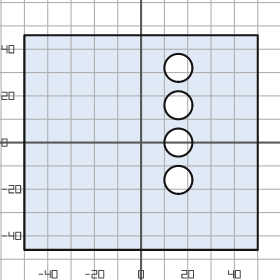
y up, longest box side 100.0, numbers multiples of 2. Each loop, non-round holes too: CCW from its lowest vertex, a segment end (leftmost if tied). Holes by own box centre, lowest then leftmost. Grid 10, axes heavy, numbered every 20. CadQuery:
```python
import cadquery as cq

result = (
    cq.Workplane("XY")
    .moveTo(-50.0, -46.0)
    .lineTo(50.0, -46.0)
    .lineTo(50.0, 46.0)
    .lineTo(-50.0, 46.0)
    .close()
    .moveTo(16.0, -16.0)
    .circle(6.0)
    .moveTo(16.0, 0.0)
    .circle(6.0)
    .moveTo(16.0, 16.0)
    .circle(6.0)
    .moveTo(16.0, 32.0)
    .circle(6.0)
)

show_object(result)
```